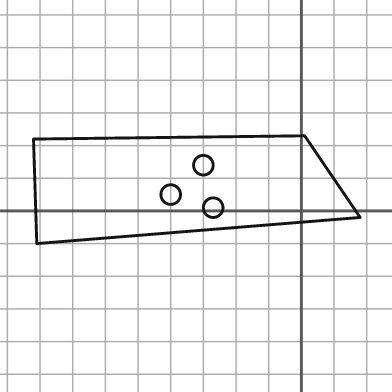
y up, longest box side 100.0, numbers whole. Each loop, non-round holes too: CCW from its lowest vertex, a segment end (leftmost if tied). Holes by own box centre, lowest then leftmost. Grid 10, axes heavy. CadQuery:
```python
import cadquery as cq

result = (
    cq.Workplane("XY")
    .moveTo(-81.0, -10.0)
    .lineTo(18.0, -2.0)
    .lineTo(1.0, 23.0)
    .lineTo(-82.0, 22.0)
    .close()
    .moveTo(-27.0, 1.0)
    .circle(3.0)
    .moveTo(-40.0, 5.0)
    .circle(3.0)
    .moveTo(-30.0, 14.0)
    .circle(3.0)
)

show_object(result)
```